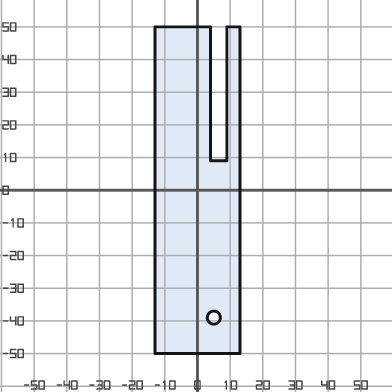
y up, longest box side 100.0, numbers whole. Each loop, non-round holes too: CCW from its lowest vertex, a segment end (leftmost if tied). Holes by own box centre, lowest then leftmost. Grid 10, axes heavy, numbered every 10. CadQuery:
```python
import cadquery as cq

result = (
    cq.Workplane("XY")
    .moveTo(-13.0, -50.0)
    .lineTo(13.0, -50.0)
    .lineTo(13.0, 50.0)
    .lineTo(9.0, 50.0)
    .lineTo(9.0, 9.0)
    .lineTo(4.0, 9.0)
    .lineTo(4.0, 50.0)
    .lineTo(-13.0, 50.0)
    .close()
    .moveTo(5.0, -39.0)
    .circle(2.0)
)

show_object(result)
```